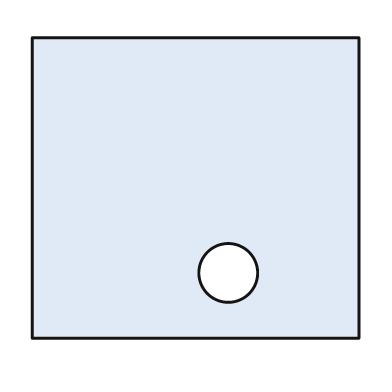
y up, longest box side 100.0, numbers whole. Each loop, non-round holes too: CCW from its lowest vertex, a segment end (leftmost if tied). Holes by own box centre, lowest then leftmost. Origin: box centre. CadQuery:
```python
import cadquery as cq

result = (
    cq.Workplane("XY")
    .moveTo(-50.0, -46.0)
    .lineTo(50.0, -46.0)
    .lineTo(50.0, 46.0)
    .lineTo(-50.0, 46.0)
    .close()
    .moveTo(10.0, -26.0)
    .circle(9.0)
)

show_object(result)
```